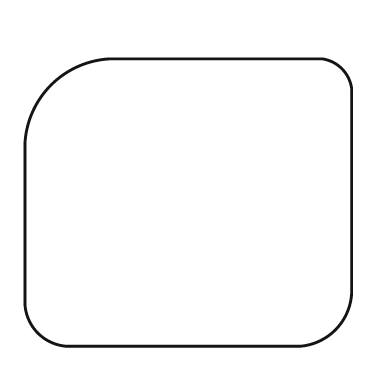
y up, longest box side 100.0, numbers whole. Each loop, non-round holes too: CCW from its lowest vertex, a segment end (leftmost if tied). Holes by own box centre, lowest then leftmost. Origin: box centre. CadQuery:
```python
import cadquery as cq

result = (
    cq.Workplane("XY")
    .moveTo(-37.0, -44.0)
    .lineTo(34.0, -44.0)
    .threePointArc((45.0, -39.0), (50.0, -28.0))
    .lineTo(50.0, 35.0)
    .threePointArc((47.0, 41.0), (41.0, 44.0))
    .lineTo(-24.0, 44.0)
    .threePointArc((-42.0, 36.0), (-50.0, 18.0))
    .lineTo(-50.0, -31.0)
    .threePointArc((-46.0, -40.0), (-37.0, -44.0))
    .close()
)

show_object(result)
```